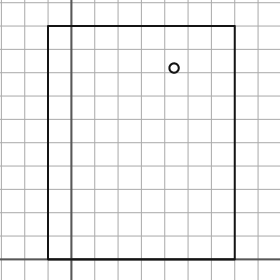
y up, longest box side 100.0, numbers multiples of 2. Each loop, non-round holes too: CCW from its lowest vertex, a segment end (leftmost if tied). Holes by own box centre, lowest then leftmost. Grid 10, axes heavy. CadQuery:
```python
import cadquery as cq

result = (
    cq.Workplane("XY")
    .moveTo(-10.0, 0.0)
    .lineTo(70.0, 0.0)
    .lineTo(70.0, 100.0)
    .lineTo(-10.0, 100.0)
    .close()
    .moveTo(44.0, 82.0)
    .circle(2.0)
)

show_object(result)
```